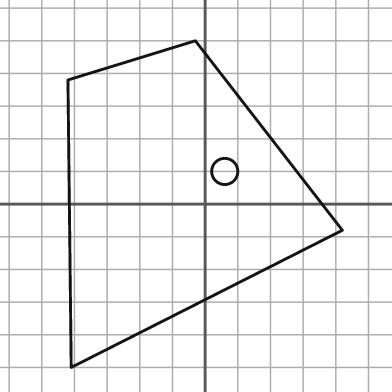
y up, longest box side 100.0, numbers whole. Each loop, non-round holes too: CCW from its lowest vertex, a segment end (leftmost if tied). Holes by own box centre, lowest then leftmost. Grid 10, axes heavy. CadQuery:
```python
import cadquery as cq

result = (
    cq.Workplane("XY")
    .moveTo(-41.0, -50.0)
    .lineTo(42.0, -8.0)
    .lineTo(-3.0, 50.0)
    .lineTo(-42.0, 38.0)
    .close()
    .moveTo(6.0, 10.0)
    .circle(4.0)
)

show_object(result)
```